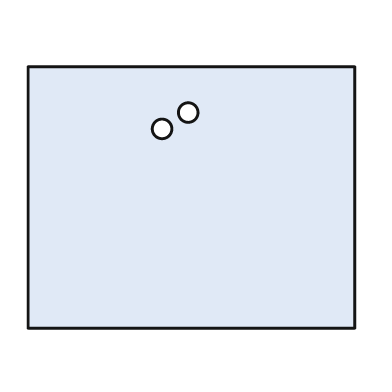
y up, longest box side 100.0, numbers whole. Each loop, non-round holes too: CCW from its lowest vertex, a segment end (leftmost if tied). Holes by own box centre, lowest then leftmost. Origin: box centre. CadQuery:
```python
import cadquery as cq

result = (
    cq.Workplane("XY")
    .moveTo(-50.0, -40.0)
    .lineTo(50.0, -40.0)
    .lineTo(50.0, 40.0)
    .lineTo(-50.0, 40.0)
    .close()
    .moveTo(-9.0, 21.0)
    .circle(3.0)
    .moveTo(-1.0, 26.0)
    .circle(3.0)
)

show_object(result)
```